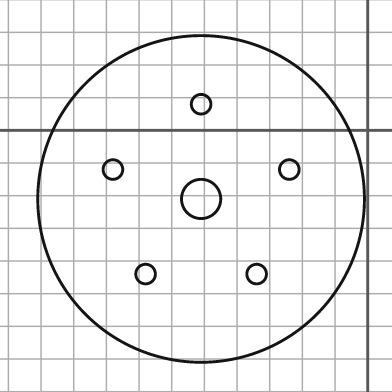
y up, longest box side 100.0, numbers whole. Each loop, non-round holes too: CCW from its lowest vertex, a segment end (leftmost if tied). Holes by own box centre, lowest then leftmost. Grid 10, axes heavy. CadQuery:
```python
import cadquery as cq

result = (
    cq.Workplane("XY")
    .moveTo(-51.0, -21.0)
    .circle(50.0)
    .moveTo(-68.0, -44.0)
    .circle(3.0)
    .moveTo(-34.0, -44.0)
    .circle(3.0)
    .moveTo(-51.0, -21.0)
    .circle(6.0)
    .moveTo(-78.0, -12.0)
    .circle(3.0)
    .moveTo(-24.0, -12.0)
    .circle(3.0)
    .moveTo(-51.0, 8.0)
    .circle(3.0)
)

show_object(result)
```